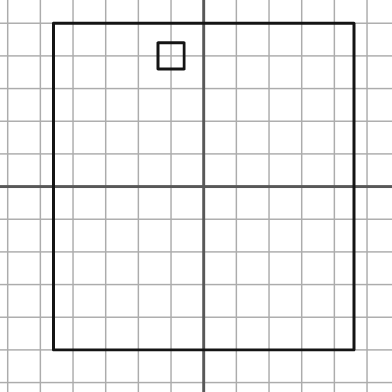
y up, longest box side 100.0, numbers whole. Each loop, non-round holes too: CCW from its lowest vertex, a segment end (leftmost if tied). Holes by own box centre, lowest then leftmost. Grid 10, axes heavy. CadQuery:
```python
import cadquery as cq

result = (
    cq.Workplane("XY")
    .moveTo(-46.0, -50.0)
    .lineTo(46.0, -50.0)
    .lineTo(46.0, 50.0)
    .lineTo(-46.0, 50.0)
    .close()
    .moveTo(-14.0, 36.0)
    .lineTo(-6.0, 36.0)
    .lineTo(-6.0, 44.0)
    .lineTo(-14.0, 44.0)
    .close()
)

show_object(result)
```